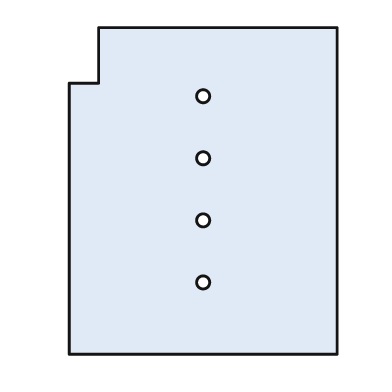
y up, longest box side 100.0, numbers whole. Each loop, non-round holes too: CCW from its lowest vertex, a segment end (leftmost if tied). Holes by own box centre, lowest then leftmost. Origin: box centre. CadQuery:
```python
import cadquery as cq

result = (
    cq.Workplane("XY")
    .moveTo(-41.0, -50.0)
    .lineTo(41.0, -50.0)
    .lineTo(41.0, 50.0)
    .lineTo(-32.0, 50.0)
    .lineTo(-32.0, 33.0)
    .lineTo(-41.0, 33.0)
    .close()
    .moveTo(0.0, -28.0)
    .circle(2.0)
    .moveTo(0.0, -9.0)
    .circle(2.0)
    .moveTo(0.0, 10.0)
    .circle(2.0)
    .moveTo(0.0, 29.0)
    .circle(2.0)
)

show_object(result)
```